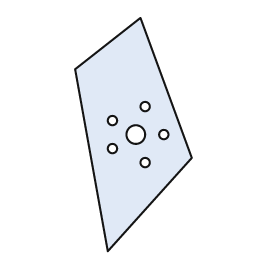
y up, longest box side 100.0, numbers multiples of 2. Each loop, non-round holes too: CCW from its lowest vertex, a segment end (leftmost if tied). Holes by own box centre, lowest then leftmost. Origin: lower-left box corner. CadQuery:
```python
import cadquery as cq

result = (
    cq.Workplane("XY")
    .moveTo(14.0, 0.0)
    .lineTo(50.0, 40.0)
    .lineTo(28.0, 100.0)
    .lineTo(0.0, 78.0)
    .close()
    .moveTo(30.0, 38.0)
    .circle(2.0)
    .moveTo(16.0, 44.0)
    .circle(2.0)
    .moveTo(26.0, 50.0)
    .circle(4.0)
    .moveTo(38.0, 50.0)
    .circle(2.0)
    .moveTo(16.0, 56.0)
    .circle(2.0)
    .moveTo(30.0, 62.0)
    .circle(2.0)
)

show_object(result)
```